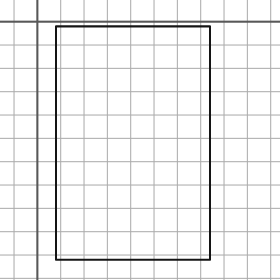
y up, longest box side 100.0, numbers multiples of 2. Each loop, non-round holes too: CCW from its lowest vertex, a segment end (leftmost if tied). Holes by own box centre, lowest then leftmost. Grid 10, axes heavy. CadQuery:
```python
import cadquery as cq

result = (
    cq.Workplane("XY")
    .moveTo(8.0, -102.0)
    .lineTo(74.0, -102.0)
    .lineTo(74.0, -2.0)
    .lineTo(8.0, -2.0)
    .close()
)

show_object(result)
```